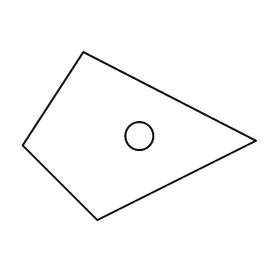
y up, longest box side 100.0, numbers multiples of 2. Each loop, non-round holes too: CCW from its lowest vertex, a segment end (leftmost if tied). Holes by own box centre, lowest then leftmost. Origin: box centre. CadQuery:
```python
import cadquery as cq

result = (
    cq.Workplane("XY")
    .moveTo(-18.0, -36.0)
    .lineTo(50.0, -2.0)
    .lineTo(-24.0, 36.0)
    .lineTo(-50.0, -4.0)
    .close()
    .moveTo(0.0, 0.0)
    .circle(6.0)
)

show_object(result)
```